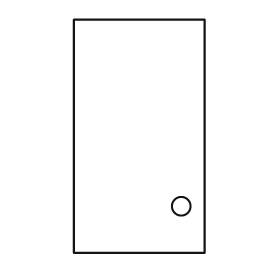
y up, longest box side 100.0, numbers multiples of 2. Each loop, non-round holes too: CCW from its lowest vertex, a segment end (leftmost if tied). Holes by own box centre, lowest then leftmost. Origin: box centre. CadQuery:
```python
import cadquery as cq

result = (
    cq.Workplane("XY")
    .moveTo(-28.0, -50.0)
    .lineTo(28.0, -50.0)
    .lineTo(28.0, 50.0)
    .lineTo(-28.0, 50.0)
    .close()
    .moveTo(18.0, -30.0)
    .circle(4.0)
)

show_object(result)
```